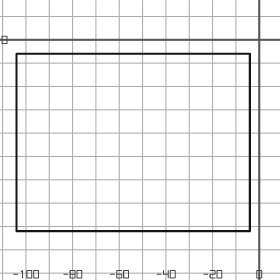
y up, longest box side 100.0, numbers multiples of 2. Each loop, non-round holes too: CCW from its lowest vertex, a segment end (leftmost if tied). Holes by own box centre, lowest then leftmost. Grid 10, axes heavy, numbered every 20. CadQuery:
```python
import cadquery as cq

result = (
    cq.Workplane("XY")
    .moveTo(-104.0, -82.0)
    .lineTo(-4.0, -82.0)
    .lineTo(-4.0, -6.0)
    .lineTo(-104.0, -6.0)
    .close()
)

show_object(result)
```